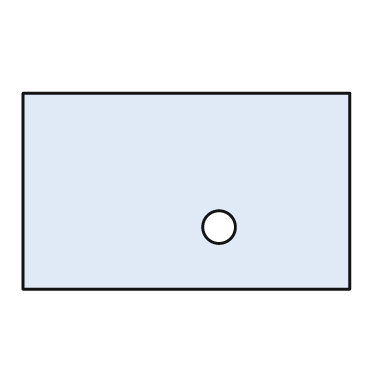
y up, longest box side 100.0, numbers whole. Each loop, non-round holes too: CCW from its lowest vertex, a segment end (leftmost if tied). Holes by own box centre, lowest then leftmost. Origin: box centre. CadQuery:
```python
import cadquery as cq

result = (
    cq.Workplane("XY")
    .moveTo(-50.0, -30.0)
    .lineTo(50.0, -30.0)
    .lineTo(50.0, 30.0)
    .lineTo(-50.0, 30.0)
    .close()
    .moveTo(10.0, -11.0)
    .circle(5.0)
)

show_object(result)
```